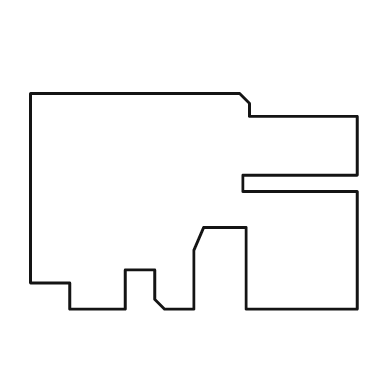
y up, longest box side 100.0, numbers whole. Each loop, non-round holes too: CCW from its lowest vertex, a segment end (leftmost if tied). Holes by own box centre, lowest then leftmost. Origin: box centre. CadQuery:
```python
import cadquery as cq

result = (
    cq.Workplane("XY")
    .moveTo(-38.0, -33.0)
    .lineTo(-21.0, -33.0)
    .lineTo(-21.0, -21.0)
    .lineTo(-12.0, -21.0)
    .lineTo(-12.0, -30.0)
    .lineTo(-9.0, -33.0)
    .lineTo(0.0, -33.0)
    .lineTo(0.0, -15.0)
    .lineTo(3.0, -8.0)
    .lineTo(16.0, -8.0)
    .lineTo(16.0, -33.0)
    .lineTo(50.0, -33.0)
    .lineTo(50.0, 3.0)
    .lineTo(15.0, 3.0)
    .lineTo(15.0, 8.0)
    .lineTo(50.0, 8.0)
    .lineTo(50.0, 26.0)
    .lineTo(17.0, 26.0)
    .lineTo(17.0, 30.0)
    .lineTo(14.0, 33.0)
    .lineTo(-50.0, 33.0)
    .lineTo(-50.0, -25.0)
    .lineTo(-38.0, -25.0)
    .close()
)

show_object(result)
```